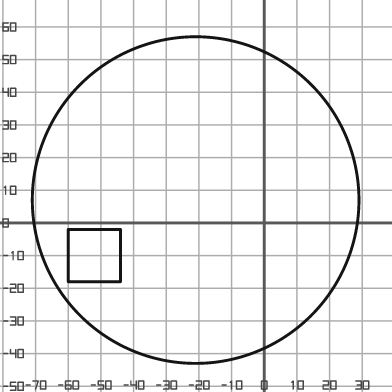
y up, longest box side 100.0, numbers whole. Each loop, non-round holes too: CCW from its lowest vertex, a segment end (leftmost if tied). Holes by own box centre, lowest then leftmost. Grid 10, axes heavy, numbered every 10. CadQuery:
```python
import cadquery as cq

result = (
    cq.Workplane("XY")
    .moveTo(-21.0, 7.0)
    .circle(50.0)
    .moveTo(-60.0, -18.0)
    .lineTo(-44.0, -18.0)
    .lineTo(-44.0, -2.0)
    .lineTo(-60.0, -2.0)
    .close()
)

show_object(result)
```